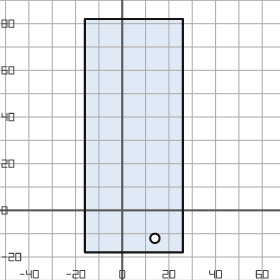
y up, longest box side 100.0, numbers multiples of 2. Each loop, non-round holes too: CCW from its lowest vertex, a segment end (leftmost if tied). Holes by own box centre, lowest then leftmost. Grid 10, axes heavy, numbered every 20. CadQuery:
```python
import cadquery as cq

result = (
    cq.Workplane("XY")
    .moveTo(-16.0, -18.0)
    .lineTo(26.0, -18.0)
    .lineTo(26.0, 82.0)
    .lineTo(-16.0, 82.0)
    .close()
    .moveTo(14.0, -12.0)
    .circle(2.0)
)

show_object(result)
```